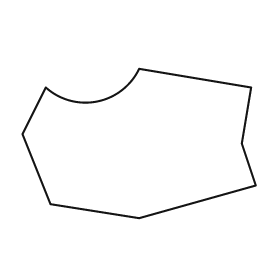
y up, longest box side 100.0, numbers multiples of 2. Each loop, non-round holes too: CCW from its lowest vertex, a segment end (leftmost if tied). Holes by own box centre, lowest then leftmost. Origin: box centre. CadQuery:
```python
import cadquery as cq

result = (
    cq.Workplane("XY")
    .moveTo(0.0, -32.0)
    .lineTo(50.0, -18.0)
    .lineTo(44.0, 0.0)
    .lineTo(48.0, 24.0)
    .lineTo(0.0, 32.0)
    .threePointArc((-18.0, 18.0), (-40.0, 24.0))
    .lineTo(-50.0, 4.0)
    .lineTo(-38.0, -26.0)
    .close()
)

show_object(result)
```